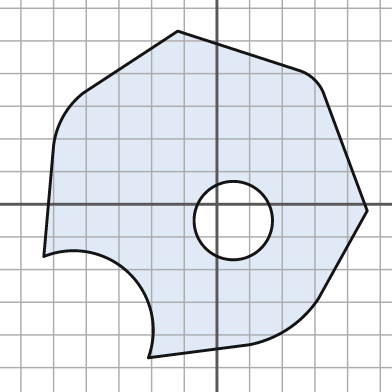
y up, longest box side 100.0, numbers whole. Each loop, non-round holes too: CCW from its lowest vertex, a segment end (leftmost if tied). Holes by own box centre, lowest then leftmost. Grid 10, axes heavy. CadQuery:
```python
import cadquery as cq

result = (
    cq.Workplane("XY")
    .moveTo(-21.0, -47.0)
    .lineTo(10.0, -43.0)
    .threePointArc((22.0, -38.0), (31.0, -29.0))
    .lineTo(46.0, -2.0)
    .lineTo(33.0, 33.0)
    .threePointArc((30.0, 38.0), (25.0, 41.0))
    .lineTo(-12.0, 53.0)
    .lineTo(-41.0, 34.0)
    .threePointArc((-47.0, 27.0), (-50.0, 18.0))
    .lineTo(-53.0, -16.0)
    .threePointArc((-27.0, -21.0), (-21.0, -47.0))
    .close()
    .moveTo(5.0, -5.0)
    .circle(12.0)
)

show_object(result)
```